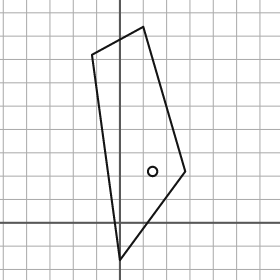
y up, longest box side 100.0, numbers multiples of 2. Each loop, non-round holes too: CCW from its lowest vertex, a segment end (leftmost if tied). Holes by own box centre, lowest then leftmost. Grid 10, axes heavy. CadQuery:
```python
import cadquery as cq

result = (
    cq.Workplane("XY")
    .moveTo(0.0, -16.0)
    .lineTo(28.0, 22.0)
    .lineTo(10.0, 84.0)
    .lineTo(-12.0, 72.0)
    .close()
    .moveTo(14.0, 22.0)
    .circle(2.0)
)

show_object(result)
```